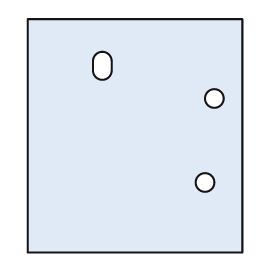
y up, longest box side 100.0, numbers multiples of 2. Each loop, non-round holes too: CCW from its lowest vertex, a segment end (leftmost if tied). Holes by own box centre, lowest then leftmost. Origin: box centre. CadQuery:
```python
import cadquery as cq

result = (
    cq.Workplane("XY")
    .moveTo(-46.0, -50.0)
    .lineTo(46.0, -50.0)
    .lineTo(46.0, 50.0)
    .lineTo(-46.0, 50.0)
    .close()
    .moveTo(30.0, -20.0)
    .circle(4.0)
    .moveTo(34.0, 16.0)
    .circle(4.0)
    .moveTo(-18.0, 28.0)
    .threePointArc((-14.0, 24.0), (-10.0, 28.0))
    .lineTo(-10.0, 32.0)
    .threePointArc((-14.0, 36.0), (-18.0, 32.0))
    .close()
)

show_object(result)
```